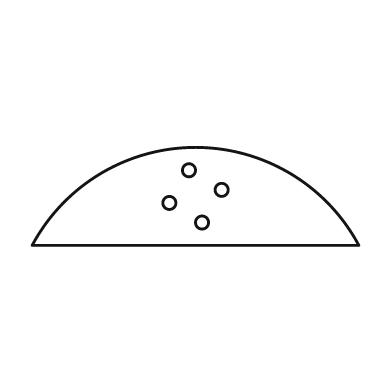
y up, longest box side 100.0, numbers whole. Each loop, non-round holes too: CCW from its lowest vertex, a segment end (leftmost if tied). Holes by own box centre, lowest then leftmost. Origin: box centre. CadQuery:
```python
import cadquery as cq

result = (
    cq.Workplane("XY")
    .moveTo(-50.0, -15.0)
    .lineTo(50.0, -15.0)
    .threePointArc((0.0, 15.0), (-50.0, -15.0))
    .close()
    .moveTo(2.0, -8.0)
    .circle(2.0)
    .moveTo(-8.0, -2.0)
    .circle(2.0)
    .moveTo(8.0, 2.0)
    .circle(2.0)
    .moveTo(-2.0, 8.0)
    .circle(2.0)
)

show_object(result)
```